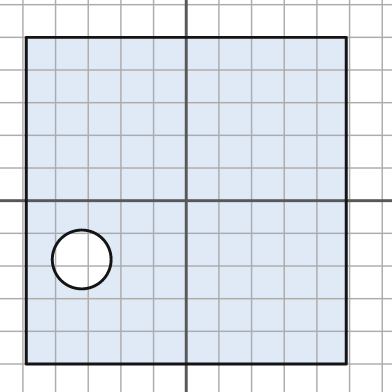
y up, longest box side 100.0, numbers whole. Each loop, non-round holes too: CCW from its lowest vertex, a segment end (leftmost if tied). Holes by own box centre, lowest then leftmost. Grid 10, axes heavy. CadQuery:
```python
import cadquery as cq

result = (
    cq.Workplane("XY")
    .moveTo(-49.0, -50.0)
    .lineTo(49.0, -50.0)
    .lineTo(49.0, 50.0)
    .lineTo(-49.0, 50.0)
    .close()
    .moveTo(-32.0, -18.0)
    .circle(9.0)
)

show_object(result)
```